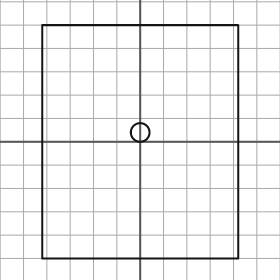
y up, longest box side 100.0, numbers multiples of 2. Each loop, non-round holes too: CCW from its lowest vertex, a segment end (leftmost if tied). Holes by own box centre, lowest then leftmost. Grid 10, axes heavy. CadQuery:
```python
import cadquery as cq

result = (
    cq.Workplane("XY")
    .moveTo(-42.0, -50.0)
    .lineTo(42.0, -50.0)
    .lineTo(42.0, 50.0)
    .lineTo(-42.0, 50.0)
    .close()
    .moveTo(0.0, 4.0)
    .circle(4.0)
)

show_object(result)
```